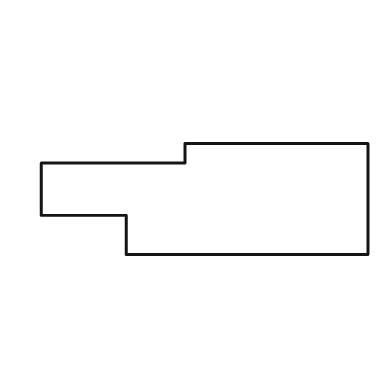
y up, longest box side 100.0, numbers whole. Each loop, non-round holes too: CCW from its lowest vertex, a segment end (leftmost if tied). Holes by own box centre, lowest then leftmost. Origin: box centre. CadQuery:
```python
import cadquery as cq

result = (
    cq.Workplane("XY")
    .moveTo(-24.0, -17.0)
    .lineTo(50.0, -17.0)
    .lineTo(50.0, 17.0)
    .lineTo(-6.0, 17.0)
    .lineTo(-6.0, 11.0)
    .lineTo(-50.0, 11.0)
    .lineTo(-50.0, -5.0)
    .lineTo(-24.0, -5.0)
    .close()
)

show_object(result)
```